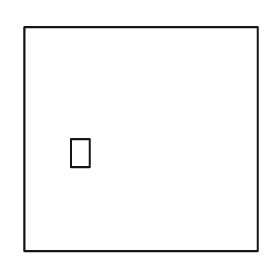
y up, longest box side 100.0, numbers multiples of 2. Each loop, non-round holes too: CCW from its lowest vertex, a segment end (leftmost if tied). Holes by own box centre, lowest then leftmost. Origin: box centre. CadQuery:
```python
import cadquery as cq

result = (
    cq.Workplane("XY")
    .moveTo(-50.0, -48.0)
    .lineTo(50.0, -48.0)
    .lineTo(50.0, 48.0)
    .lineTo(-50.0, 48.0)
    .close()
    .moveTo(-30.0, -12.0)
    .lineTo(-22.0, -12.0)
    .lineTo(-22.0, 0.0)
    .lineTo(-30.0, 0.0)
    .close()
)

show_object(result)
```